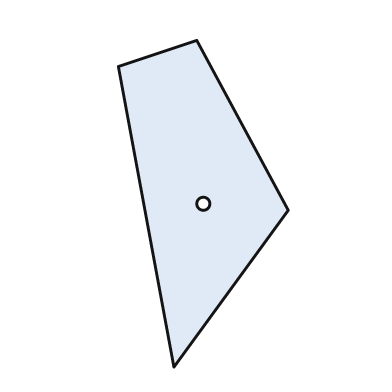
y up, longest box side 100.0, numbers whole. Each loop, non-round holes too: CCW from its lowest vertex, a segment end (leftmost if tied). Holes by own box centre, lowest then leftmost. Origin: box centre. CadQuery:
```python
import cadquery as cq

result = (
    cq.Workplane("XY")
    .moveTo(-9.0, -50.0)
    .lineTo(26.0, -2.0)
    .lineTo(-2.0, 50.0)
    .lineTo(-26.0, 42.0)
    .close()
    .moveTo(0.0, 0.0)
    .circle(2.0)
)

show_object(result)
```